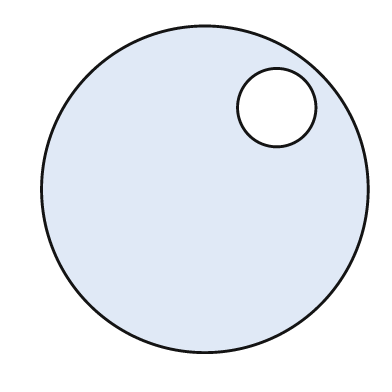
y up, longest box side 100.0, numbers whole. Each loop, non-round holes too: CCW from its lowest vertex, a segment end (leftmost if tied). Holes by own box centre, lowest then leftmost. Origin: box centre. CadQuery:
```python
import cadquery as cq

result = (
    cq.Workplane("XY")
    .moveTo(0.0, 0.0)
    .circle(50.0)
    .moveTo(22.0, 25.0)
    .circle(12.0)
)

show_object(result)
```